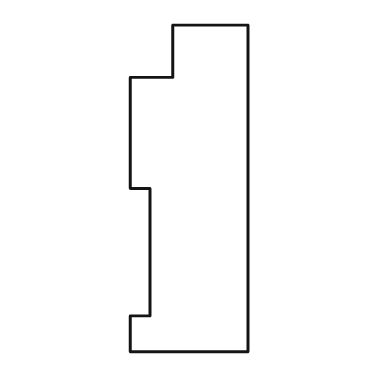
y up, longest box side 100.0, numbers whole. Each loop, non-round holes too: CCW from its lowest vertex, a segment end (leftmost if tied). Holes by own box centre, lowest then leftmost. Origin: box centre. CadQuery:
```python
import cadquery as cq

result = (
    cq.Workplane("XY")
    .moveTo(-18.0, -50.0)
    .lineTo(18.0, -50.0)
    .lineTo(18.0, 50.0)
    .lineTo(-5.0, 50.0)
    .lineTo(-5.0, 34.0)
    .lineTo(-18.0, 34.0)
    .lineTo(-18.0, 0.0)
    .lineTo(-12.0, 0.0)
    .lineTo(-12.0, -39.0)
    .lineTo(-18.0, -39.0)
    .close()
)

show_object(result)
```